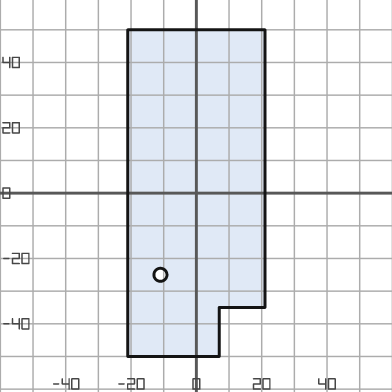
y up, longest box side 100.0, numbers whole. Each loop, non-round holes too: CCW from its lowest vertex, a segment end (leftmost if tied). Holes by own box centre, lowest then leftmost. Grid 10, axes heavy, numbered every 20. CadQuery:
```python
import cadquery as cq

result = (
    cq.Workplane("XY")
    .moveTo(-21.0, -50.0)
    .lineTo(7.0, -50.0)
    .lineTo(7.0, -35.0)
    .lineTo(21.0, -35.0)
    .lineTo(21.0, 50.0)
    .lineTo(-21.0, 50.0)
    .close()
    .moveTo(-11.0, -25.0)
    .circle(2.0)
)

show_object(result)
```